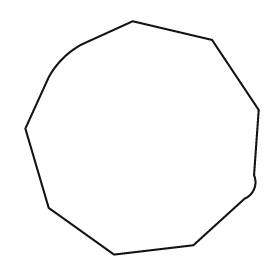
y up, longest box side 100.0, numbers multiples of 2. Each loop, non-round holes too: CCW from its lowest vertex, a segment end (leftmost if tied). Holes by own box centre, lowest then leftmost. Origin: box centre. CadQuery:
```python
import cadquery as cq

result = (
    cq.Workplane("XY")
    .moveTo(-12.0, -50.0)
    .lineTo(22.0, -46.0)
    .lineTo(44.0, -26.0)
    .threePointArc((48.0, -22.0), (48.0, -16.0))
    .lineTo(50.0, 12.0)
    .lineTo(30.0, 42.0)
    .lineTo(-4.0, 50.0)
    .lineTo(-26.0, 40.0)
    .threePointArc((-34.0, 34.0), (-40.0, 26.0))
    .lineTo(-50.0, 4.0)
    .lineTo(-40.0, -30.0)
    .close()
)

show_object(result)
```